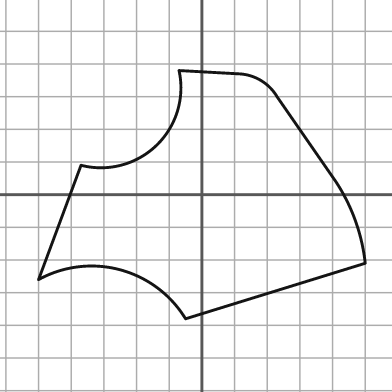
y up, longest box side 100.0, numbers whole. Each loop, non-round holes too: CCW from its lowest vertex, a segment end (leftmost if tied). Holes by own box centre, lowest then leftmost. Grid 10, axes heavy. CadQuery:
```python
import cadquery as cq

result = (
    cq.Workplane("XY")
    .moveTo(-5.0, -38.0)
    .lineTo(50.0, -21.0)
    .threePointArc((47.0, -8.0), (41.0, 4.0))
    .lineTo(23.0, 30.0)
    .threePointArc((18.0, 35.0), (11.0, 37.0))
    .lineTo(-7.0, 38.0)
    .threePointArc((-14.0, 15.0), (-37.0, 9.0))
    .lineTo(-50.0, -26.0)
    .threePointArc((-25.0, -23.0), (-5.0, -38.0))
    .close()
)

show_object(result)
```